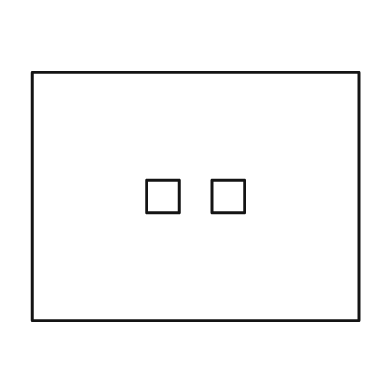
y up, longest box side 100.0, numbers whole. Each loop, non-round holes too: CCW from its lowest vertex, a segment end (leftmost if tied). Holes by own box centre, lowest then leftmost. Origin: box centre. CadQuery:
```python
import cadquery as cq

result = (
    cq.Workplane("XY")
    .moveTo(-50.0, -38.0)
    .lineTo(50.0, -38.0)
    .lineTo(50.0, 38.0)
    .lineTo(-50.0, 38.0)
    .close()
    .moveTo(-15.0, -5.0)
    .lineTo(-5.0, -5.0)
    .lineTo(-5.0, 5.0)
    .lineTo(-15.0, 5.0)
    .close()
    .moveTo(5.0, -5.0)
    .lineTo(15.0, -5.0)
    .lineTo(15.0, 5.0)
    .lineTo(5.0, 5.0)
    .close()
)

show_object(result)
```